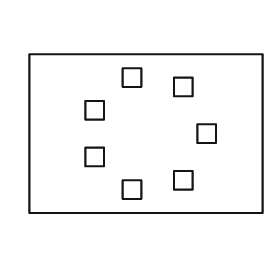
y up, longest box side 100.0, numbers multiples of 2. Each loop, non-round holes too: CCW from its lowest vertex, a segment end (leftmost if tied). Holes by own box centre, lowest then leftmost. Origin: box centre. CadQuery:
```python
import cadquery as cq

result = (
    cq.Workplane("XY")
    .moveTo(-50.0, -34.0)
    .lineTo(50.0, -34.0)
    .lineTo(50.0, 34.0)
    .lineTo(-50.0, 34.0)
    .close()
    .moveTo(-10.0, -28.0)
    .lineTo(-2.0, -28.0)
    .lineTo(-2.0, -20.0)
    .lineTo(-10.0, -20.0)
    .close()
    .moveTo(12.0, -24.0)
    .lineTo(20.0, -24.0)
    .lineTo(20.0, -16.0)
    .lineTo(12.0, -16.0)
    .close()
    .moveTo(-26.0, -14.0)
    .lineTo(-18.0, -14.0)
    .lineTo(-18.0, -6.0)
    .lineTo(-26.0, -6.0)
    .close()
    .moveTo(22.0, -4.0)
    .lineTo(30.0, -4.0)
    .lineTo(30.0, 4.0)
    .lineTo(22.0, 4.0)
    .close()
    .moveTo(-26.0, 6.0)
    .lineTo(-18.0, 6.0)
    .lineTo(-18.0, 14.0)
    .lineTo(-26.0, 14.0)
    .close()
    .moveTo(12.0, 16.0)
    .lineTo(20.0, 16.0)
    .lineTo(20.0, 24.0)
    .lineTo(12.0, 24.0)
    .close()
    .moveTo(-10.0, 20.0)
    .lineTo(-2.0, 20.0)
    .lineTo(-2.0, 28.0)
    .lineTo(-10.0, 28.0)
    .close()
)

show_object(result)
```